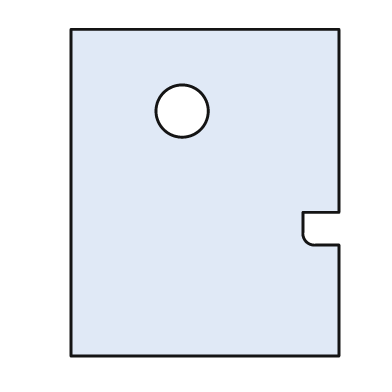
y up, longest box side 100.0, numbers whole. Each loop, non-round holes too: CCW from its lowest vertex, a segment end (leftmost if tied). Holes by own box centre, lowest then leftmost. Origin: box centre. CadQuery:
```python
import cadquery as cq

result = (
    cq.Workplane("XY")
    .moveTo(-41.0, -50.0)
    .lineTo(41.0, -50.0)
    .lineTo(41.0, -16.0)
    .lineTo(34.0, -16.0)
    .threePointArc((31.0, -15.0), (30.0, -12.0))
    .lineTo(30.0, -6.0)
    .lineTo(41.0, -6.0)
    .lineTo(41.0, 50.0)
    .lineTo(-41.0, 50.0)
    .close()
    .moveTo(-7.0, 25.0)
    .circle(8.0)
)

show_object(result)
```